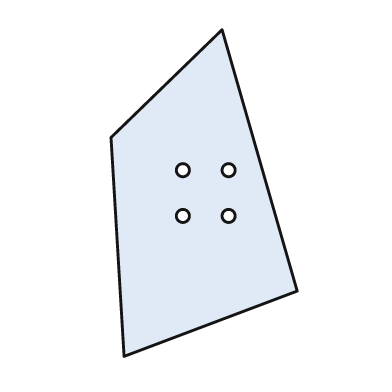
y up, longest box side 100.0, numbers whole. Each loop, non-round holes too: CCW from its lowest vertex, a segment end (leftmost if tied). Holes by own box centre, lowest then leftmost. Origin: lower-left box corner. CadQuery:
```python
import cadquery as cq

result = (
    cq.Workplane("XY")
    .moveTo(4.0, 0.0)
    .lineTo(57.0, 20.0)
    .lineTo(34.0, 100.0)
    .lineTo(0.0, 67.0)
    .close()
    .moveTo(22.0, 43.0)
    .circle(2.0)
    .moveTo(36.0, 43.0)
    .circle(2.0)
    .moveTo(22.0, 57.0)
    .circle(2.0)
    .moveTo(36.0, 57.0)
    .circle(2.0)
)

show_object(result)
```